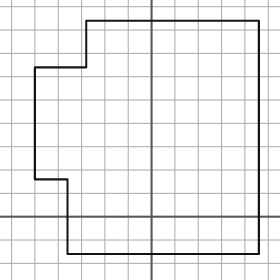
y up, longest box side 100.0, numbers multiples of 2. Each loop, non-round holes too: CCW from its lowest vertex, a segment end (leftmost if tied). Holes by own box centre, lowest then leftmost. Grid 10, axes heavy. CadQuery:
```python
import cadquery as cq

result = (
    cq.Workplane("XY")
    .moveTo(-36.0, -16.0)
    .lineTo(46.0, -16.0)
    .lineTo(46.0, 84.0)
    .lineTo(-28.0, 84.0)
    .lineTo(-28.0, 64.0)
    .lineTo(-50.0, 64.0)
    .lineTo(-50.0, 16.0)
    .lineTo(-36.0, 16.0)
    .close()
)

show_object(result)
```